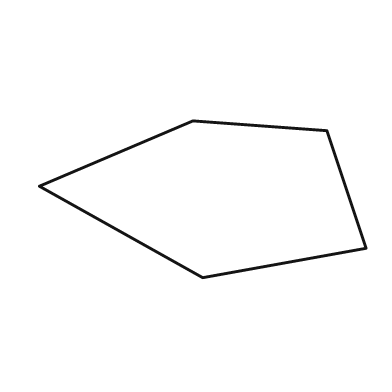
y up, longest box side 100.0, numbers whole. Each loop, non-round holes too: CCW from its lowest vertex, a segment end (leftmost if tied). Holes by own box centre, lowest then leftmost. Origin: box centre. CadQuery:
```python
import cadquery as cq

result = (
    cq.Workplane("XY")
    .moveTo(0.0, -24.0)
    .lineTo(50.0, -15.0)
    .lineTo(38.0, 21.0)
    .lineTo(-3.0, 24.0)
    .lineTo(-50.0, 4.0)
    .close()
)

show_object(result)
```